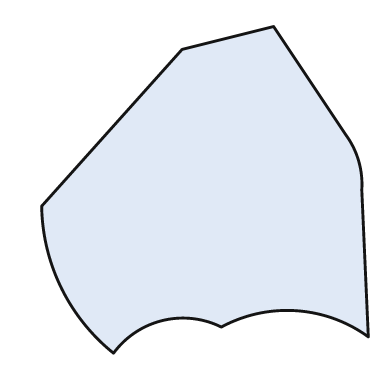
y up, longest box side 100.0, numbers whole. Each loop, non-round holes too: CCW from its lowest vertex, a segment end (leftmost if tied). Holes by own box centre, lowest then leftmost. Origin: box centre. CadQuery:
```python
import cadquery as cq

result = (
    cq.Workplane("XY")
    .moveTo(-28.0, -50.0)
    .threePointArc((-13.0, -40.0), (5.0, -42.0))
    .threePointArc((28.0, -37.0), (50.0, -45.0))
    .lineTo(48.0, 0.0)
    .threePointArc((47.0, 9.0), (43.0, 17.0))
    .lineTo(21.0, 50.0)
    .lineTo(-7.0, 43.0)
    .lineTo(-50.0, -5.0)
    .threePointArc((-44.0, -30.0), (-28.0, -50.0))
    .close()
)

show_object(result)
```